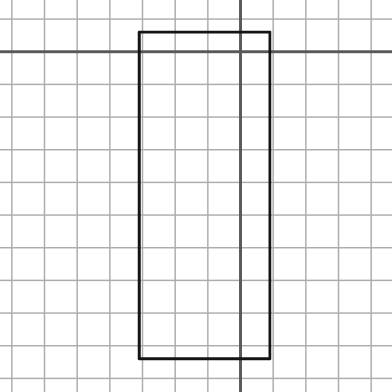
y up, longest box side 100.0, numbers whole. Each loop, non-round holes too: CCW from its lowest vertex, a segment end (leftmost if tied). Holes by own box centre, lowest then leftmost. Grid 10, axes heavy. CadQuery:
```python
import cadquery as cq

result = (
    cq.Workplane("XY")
    .moveTo(-31.0, -94.0)
    .lineTo(9.0, -94.0)
    .lineTo(9.0, 6.0)
    .lineTo(-31.0, 6.0)
    .close()
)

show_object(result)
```